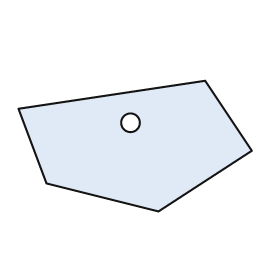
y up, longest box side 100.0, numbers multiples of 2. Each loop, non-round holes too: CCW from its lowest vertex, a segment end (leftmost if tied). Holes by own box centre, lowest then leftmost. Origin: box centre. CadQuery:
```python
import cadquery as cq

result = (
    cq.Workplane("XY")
    .moveTo(10.0, -28.0)
    .lineTo(50.0, -2.0)
    .lineTo(30.0, 28.0)
    .lineTo(-50.0, 16.0)
    .lineTo(-38.0, -16.0)
    .close()
    .moveTo(-2.0, 10.0)
    .circle(4.0)
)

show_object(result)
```